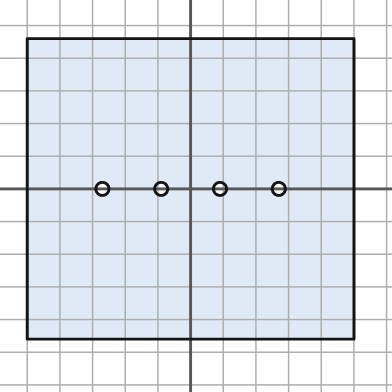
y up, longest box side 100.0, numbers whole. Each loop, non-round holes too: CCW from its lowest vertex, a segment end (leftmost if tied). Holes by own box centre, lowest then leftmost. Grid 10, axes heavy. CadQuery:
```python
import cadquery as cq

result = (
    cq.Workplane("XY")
    .moveTo(-50.0, -46.0)
    .lineTo(50.0, -46.0)
    .lineTo(50.0, 46.0)
    .lineTo(-50.0, 46.0)
    .close()
    .moveTo(-27.0, 0.0)
    .circle(2.0)
    .moveTo(-9.0, 0.0)
    .circle(2.0)
    .moveTo(9.0, 0.0)
    .circle(2.0)
    .moveTo(27.0, 0.0)
    .circle(2.0)
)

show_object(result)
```